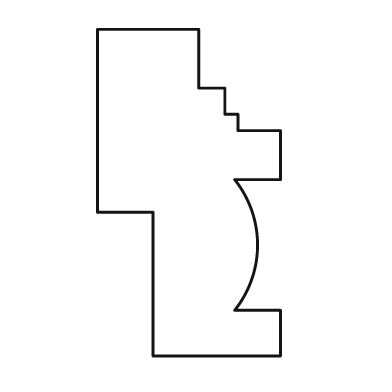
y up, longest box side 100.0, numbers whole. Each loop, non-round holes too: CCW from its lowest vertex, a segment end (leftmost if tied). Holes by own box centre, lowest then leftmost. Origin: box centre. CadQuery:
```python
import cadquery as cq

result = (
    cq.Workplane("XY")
    .moveTo(-11.0, -50.0)
    .lineTo(28.0, -50.0)
    .lineTo(28.0, -36.0)
    .lineTo(14.0, -36.0)
    .threePointArc((21.0, -16.0), (14.0, 4.0))
    .lineTo(28.0, 4.0)
    .lineTo(28.0, 19.0)
    .lineTo(15.0, 19.0)
    .lineTo(15.0, 24.0)
    .lineTo(11.0, 24.0)
    .lineTo(11.0, 32.0)
    .lineTo(3.0, 32.0)
    .lineTo(3.0, 50.0)
    .lineTo(-28.0, 50.0)
    .lineTo(-28.0, -6.0)
    .lineTo(-11.0, -6.0)
    .close()
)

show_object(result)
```